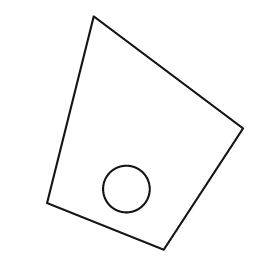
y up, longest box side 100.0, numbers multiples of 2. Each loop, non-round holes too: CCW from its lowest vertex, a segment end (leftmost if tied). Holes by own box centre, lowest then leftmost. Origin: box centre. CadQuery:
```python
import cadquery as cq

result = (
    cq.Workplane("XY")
    .moveTo(8.0, -50.0)
    .lineTo(42.0, 2.0)
    .lineTo(-22.0, 50.0)
    .lineTo(-42.0, -30.0)
    .close()
    .moveTo(-8.0, -24.0)
    .circle(10.0)
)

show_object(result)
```